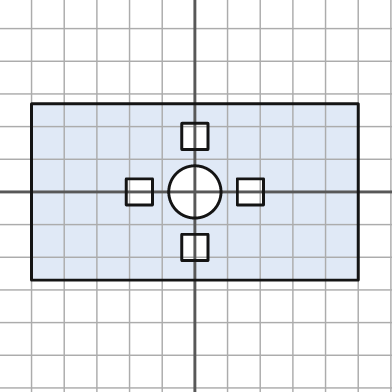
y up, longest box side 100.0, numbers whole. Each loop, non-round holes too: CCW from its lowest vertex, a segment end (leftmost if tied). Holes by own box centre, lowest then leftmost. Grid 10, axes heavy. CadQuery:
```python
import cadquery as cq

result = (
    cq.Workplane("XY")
    .moveTo(-50.0, -27.0)
    .lineTo(50.0, -27.0)
    .lineTo(50.0, 27.0)
    .lineTo(-50.0, 27.0)
    .close()
    .moveTo(-4.0, -21.0)
    .lineTo(4.0, -21.0)
    .lineTo(4.0, -13.0)
    .lineTo(-4.0, -13.0)
    .close()
    .moveTo(-21.0, -4.0)
    .lineTo(-13.0, -4.0)
    .lineTo(-13.0, 4.0)
    .lineTo(-21.0, 4.0)
    .close()
    .moveTo(0.0, 0.0)
    .circle(8.0)
    .moveTo(13.0, -4.0)
    .lineTo(21.0, -4.0)
    .lineTo(21.0, 4.0)
    .lineTo(13.0, 4.0)
    .close()
    .moveTo(-4.0, 13.0)
    .lineTo(4.0, 13.0)
    .lineTo(4.0, 21.0)
    .lineTo(-4.0, 21.0)
    .close()
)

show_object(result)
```